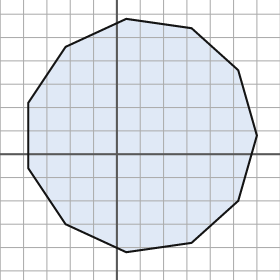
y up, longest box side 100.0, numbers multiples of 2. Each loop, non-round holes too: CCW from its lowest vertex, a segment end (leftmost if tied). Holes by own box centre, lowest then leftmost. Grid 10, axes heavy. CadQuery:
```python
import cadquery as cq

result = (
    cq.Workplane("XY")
    .moveTo(4.0, -42.0)
    .lineTo(32.0, -38.0)
    .lineTo(52.0, -20.0)
    .lineTo(60.0, 8.0)
    .lineTo(52.0, 36.0)
    .lineTo(32.0, 54.0)
    .lineTo(4.0, 58.0)
    .lineTo(-22.0, 46.0)
    .lineTo(-38.0, 22.0)
    .lineTo(-38.0, -6.0)
    .lineTo(-22.0, -30.0)
    .close()
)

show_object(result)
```